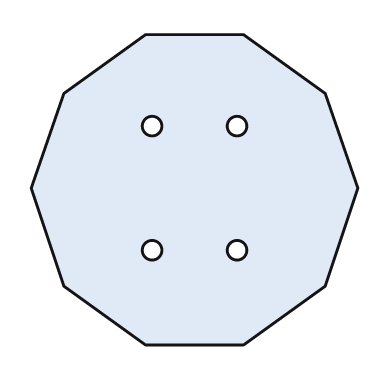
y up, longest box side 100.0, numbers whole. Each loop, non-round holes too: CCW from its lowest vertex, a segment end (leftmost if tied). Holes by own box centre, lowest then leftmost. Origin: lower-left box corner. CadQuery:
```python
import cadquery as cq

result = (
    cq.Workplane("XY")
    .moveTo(35.0, 0.0)
    .lineTo(65.0, 0.0)
    .lineTo(90.0, 18.0)
    .lineTo(100.0, 48.0)
    .lineTo(90.0, 77.0)
    .lineTo(65.0, 95.0)
    .lineTo(35.0, 95.0)
    .lineTo(10.0, 77.0)
    .lineTo(0.0, 48.0)
    .lineTo(10.0, 18.0)
    .close()
    .moveTo(37.0, 29.0)
    .circle(3.0)
    .moveTo(63.0, 29.0)
    .circle(3.0)
    .moveTo(37.0, 67.0)
    .circle(3.0)
    .moveTo(63.0, 67.0)
    .circle(3.0)
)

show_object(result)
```